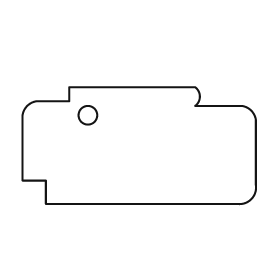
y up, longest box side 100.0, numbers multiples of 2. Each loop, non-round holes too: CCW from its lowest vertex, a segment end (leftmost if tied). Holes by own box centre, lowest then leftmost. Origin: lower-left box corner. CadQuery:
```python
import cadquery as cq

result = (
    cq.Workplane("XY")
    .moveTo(10.0, 0.0)
    .lineTo(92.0, 0.0)
    .threePointArc((98.0, 2.0), (100.0, 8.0))
    .lineTo(100.0, 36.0)
    .threePointArc((98.0, 40.0), (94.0, 42.0))
    .lineTo(74.0, 42.0)
    .threePointArc((76.0, 46.0), (74.0, 50.0))
    .lineTo(20.0, 50.0)
    .lineTo(20.0, 44.0)
    .lineTo(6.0, 44.0)
    .threePointArc((2.0, 42.0), (0.0, 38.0))
    .lineTo(0.0, 10.0)
    .lineTo(10.0, 10.0)
    .close()
    .moveTo(28.0, 38.0)
    .circle(4.0)
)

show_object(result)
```